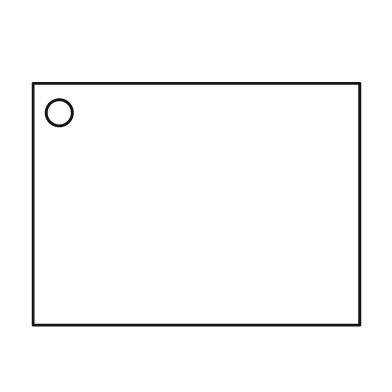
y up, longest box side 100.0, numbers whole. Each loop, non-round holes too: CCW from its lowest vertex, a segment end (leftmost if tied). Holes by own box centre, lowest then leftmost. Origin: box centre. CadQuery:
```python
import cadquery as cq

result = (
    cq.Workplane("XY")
    .moveTo(-50.0, -37.0)
    .lineTo(50.0, -37.0)
    .lineTo(50.0, 37.0)
    .lineTo(-50.0, 37.0)
    .close()
    .moveTo(-42.0, 28.0)
    .circle(4.0)
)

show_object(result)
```